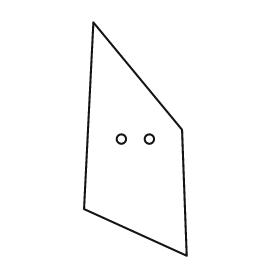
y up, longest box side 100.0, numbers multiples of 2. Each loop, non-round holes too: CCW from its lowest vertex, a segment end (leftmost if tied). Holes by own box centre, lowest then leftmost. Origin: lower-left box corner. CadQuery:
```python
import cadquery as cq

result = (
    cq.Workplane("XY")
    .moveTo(44.0, 0.0)
    .lineTo(42.0, 54.0)
    .lineTo(4.0, 100.0)
    .lineTo(0.0, 20.0)
    .close()
    .moveTo(16.0, 50.0)
    .circle(2.0)
    .moveTo(28.0, 50.0)
    .circle(2.0)
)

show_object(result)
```